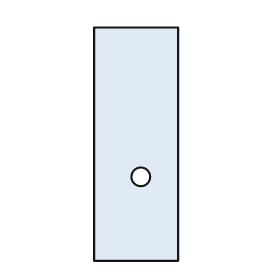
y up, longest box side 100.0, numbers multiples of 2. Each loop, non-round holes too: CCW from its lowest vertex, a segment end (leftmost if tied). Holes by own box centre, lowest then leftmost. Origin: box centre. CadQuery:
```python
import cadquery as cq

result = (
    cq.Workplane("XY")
    .moveTo(-18.0, -50.0)
    .lineTo(18.0, -50.0)
    .lineTo(18.0, 50.0)
    .lineTo(-18.0, 50.0)
    .close()
    .moveTo(2.0, -14.0)
    .circle(4.0)
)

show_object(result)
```